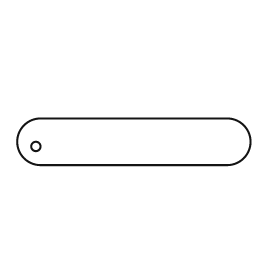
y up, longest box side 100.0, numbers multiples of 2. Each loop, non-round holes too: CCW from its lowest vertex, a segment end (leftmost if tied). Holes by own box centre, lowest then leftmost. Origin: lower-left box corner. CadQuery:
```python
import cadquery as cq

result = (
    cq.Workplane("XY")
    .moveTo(10.0, 0.0)
    .lineTo(90.0, 0.0)
    .threePointArc((100.0, 10.0), (90.0, 20.0))
    .lineTo(10.0, 20.0)
    .threePointArc((0.0, 10.0), (10.0, 0.0))
    .close()
    .moveTo(8.0, 8.0)
    .circle(2.0)
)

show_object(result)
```